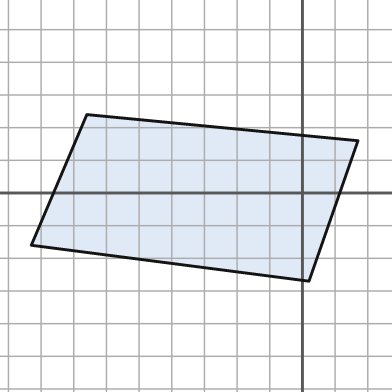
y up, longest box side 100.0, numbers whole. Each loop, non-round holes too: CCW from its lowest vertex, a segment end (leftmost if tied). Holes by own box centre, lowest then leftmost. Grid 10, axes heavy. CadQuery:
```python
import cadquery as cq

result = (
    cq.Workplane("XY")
    .moveTo(2.0, -27.0)
    .lineTo(17.0, 16.0)
    .lineTo(-66.0, 24.0)
    .lineTo(-83.0, -16.0)
    .close()
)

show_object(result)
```